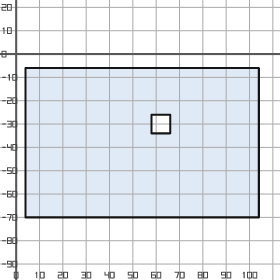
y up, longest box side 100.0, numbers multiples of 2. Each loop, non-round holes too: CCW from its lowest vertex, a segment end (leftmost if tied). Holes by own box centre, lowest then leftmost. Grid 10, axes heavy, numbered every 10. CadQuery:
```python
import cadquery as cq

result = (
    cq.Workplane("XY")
    .moveTo(4.0, -70.0)
    .lineTo(104.0, -70.0)
    .lineTo(104.0, -6.0)
    .lineTo(4.0, -6.0)
    .close()
    .moveTo(58.0, -34.0)
    .lineTo(66.0, -34.0)
    .lineTo(66.0, -26.0)
    .lineTo(58.0, -26.0)
    .close()
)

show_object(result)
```